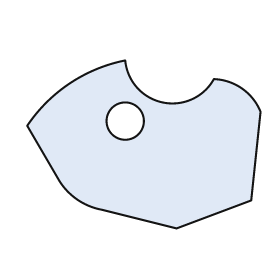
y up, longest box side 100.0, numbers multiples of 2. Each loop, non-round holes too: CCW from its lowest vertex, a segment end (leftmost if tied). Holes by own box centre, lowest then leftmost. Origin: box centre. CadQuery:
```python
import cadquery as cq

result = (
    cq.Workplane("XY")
    .moveTo(14.0, -36.0)
    .lineTo(46.0, -24.0)
    .lineTo(50.0, 14.0)
    .threePointArc((42.0, 24.0), (30.0, 28.0))
    .threePointArc((8.0, 18.0), (-8.0, 36.0))
    .threePointArc((-32.0, 26.0), (-50.0, 8.0))
    .lineTo(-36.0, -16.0)
    .threePointArc((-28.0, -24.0), (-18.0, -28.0))
    .close()
    .moveTo(-8.0, 10.0)
    .circle(8.0)
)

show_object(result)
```